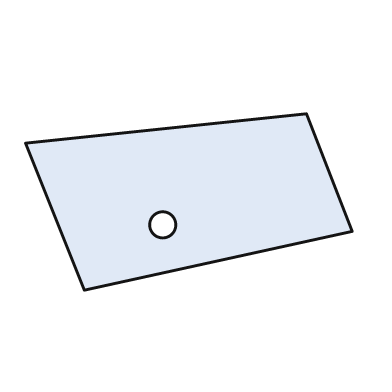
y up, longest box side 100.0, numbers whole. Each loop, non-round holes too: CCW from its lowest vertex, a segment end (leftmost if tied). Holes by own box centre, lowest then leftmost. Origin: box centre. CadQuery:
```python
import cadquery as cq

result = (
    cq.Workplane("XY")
    .moveTo(-32.0, -27.0)
    .lineTo(50.0, -9.0)
    .lineTo(36.0, 27.0)
    .lineTo(-50.0, 18.0)
    .close()
    .moveTo(-8.0, -7.0)
    .circle(4.0)
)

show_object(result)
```